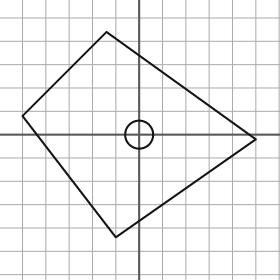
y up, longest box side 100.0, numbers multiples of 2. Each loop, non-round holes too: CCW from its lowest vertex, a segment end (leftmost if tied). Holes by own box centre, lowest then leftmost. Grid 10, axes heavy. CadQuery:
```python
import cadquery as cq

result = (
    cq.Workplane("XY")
    .moveTo(-10.0, -44.0)
    .lineTo(50.0, -2.0)
    .lineTo(-14.0, 44.0)
    .lineTo(-50.0, 8.0)
    .close()
    .moveTo(0.0, 0.0)
    .circle(6.0)
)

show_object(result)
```